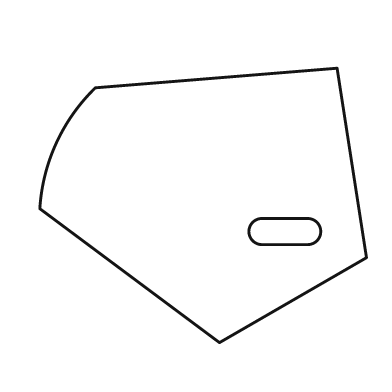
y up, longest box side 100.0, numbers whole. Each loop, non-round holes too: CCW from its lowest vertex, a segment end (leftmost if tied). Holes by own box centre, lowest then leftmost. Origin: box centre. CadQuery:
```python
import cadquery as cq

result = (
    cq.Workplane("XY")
    .moveTo(5.0, -42.0)
    .lineTo(50.0, -16.0)
    .lineTo(41.0, 42.0)
    .lineTo(-33.0, 36.0)
    .threePointArc((-45.0, 19.0), (-50.0, -1.0))
    .close()
    .moveTo(18.0, -12.0)
    .lineTo(32.0, -12.0)
    .threePointArc((36.0, -8.0), (32.0, -4.0))
    .lineTo(18.0, -4.0)
    .threePointArc((14.0, -8.0), (18.0, -12.0))
    .close()
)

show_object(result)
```